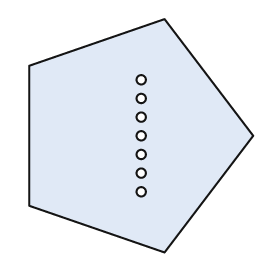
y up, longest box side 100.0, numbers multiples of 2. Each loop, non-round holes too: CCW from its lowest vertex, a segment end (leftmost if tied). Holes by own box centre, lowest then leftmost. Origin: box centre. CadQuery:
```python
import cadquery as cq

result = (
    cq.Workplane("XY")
    .moveTo(10.0, -50.0)
    .lineTo(48.0, 0.0)
    .lineTo(10.0, 50.0)
    .lineTo(-48.0, 30.0)
    .lineTo(-48.0, -30.0)
    .close()
    .moveTo(0.0, -24.0)
    .circle(2.0)
    .moveTo(0.0, -16.0)
    .circle(2.0)
    .moveTo(0.0, -8.0)
    .circle(2.0)
    .moveTo(0.0, 0.0)
    .circle(2.0)
    .moveTo(0.0, 8.0)
    .circle(2.0)
    .moveTo(0.0, 16.0)
    .circle(2.0)
    .moveTo(0.0, 24.0)
    .circle(2.0)
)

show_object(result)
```